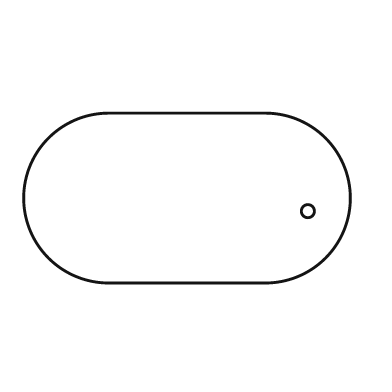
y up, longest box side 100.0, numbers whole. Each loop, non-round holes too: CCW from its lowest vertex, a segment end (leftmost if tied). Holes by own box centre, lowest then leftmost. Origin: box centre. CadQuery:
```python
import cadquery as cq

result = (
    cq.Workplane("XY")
    .moveTo(-24.0, -26.0)
    .lineTo(24.0, -26.0)
    .threePointArc((50.0, 0.0), (24.0, 26.0))
    .lineTo(-24.0, 26.0)
    .threePointArc((-50.0, 0.0), (-24.0, -26.0))
    .close()
    .moveTo(37.0, -4.0)
    .circle(2.0)
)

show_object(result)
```